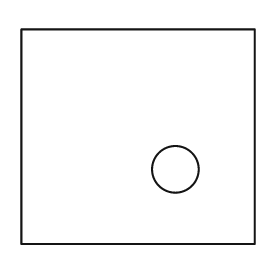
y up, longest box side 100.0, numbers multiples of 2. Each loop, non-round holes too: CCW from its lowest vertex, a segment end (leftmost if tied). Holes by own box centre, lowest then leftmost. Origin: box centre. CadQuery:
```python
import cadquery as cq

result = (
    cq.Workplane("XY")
    .moveTo(-50.0, -46.0)
    .lineTo(50.0, -46.0)
    .lineTo(50.0, 46.0)
    .lineTo(-50.0, 46.0)
    .close()
    .moveTo(16.0, -14.0)
    .circle(10.0)
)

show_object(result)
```